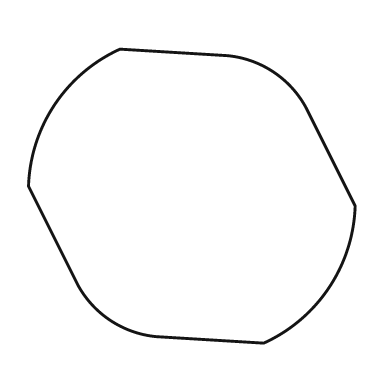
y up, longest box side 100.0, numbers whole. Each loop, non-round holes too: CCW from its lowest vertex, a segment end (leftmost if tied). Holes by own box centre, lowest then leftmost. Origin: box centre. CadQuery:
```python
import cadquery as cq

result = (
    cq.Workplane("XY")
    .moveTo(22.0, -45.0)
    .threePointArc((42.0, -28.0), (50.0, -3.0))
    .lineTo(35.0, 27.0)
    .threePointArc((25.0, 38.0), (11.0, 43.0))
    .lineTo(-22.0, 45.0)
    .threePointArc((-42.0, 28.0), (-50.0, 3.0))
    .lineTo(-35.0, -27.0)
    .threePointArc((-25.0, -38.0), (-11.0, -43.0))
    .close()
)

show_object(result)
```